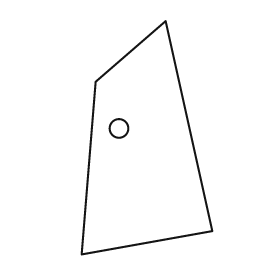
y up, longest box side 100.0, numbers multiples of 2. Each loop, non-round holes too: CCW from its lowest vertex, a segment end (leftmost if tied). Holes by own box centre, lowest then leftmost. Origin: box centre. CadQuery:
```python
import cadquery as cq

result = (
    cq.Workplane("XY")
    .moveTo(-28.0, -50.0)
    .lineTo(28.0, -40.0)
    .lineTo(8.0, 50.0)
    .lineTo(-22.0, 24.0)
    .close()
    .moveTo(-12.0, 4.0)
    .circle(4.0)
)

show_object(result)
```